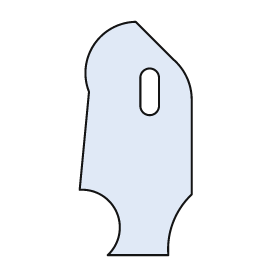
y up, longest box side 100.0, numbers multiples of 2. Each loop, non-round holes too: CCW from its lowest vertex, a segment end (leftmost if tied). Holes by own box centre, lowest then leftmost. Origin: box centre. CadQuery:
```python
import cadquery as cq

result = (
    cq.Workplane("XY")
    .moveTo(-12.0, -50.0)
    .lineTo(14.0, -50.0)
    .threePointArc((16.0, -36.0), (24.0, -24.0))
    .lineTo(24.0, 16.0)
    .threePointArc((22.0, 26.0), (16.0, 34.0))
    .lineTo(0.0, 50.0)
    .threePointArc((-18.0, 40.0), (-20.0, 20.0))
    .lineTo(-24.0, -22.0)
    .threePointArc((-8.0, -32.0), (-12.0, -50.0))
    .close()
    .moveTo(2.0, 14.0)
    .threePointArc((6.0, 10.0), (10.0, 14.0))
    .lineTo(10.0, 26.0)
    .threePointArc((6.0, 30.0), (2.0, 26.0))
    .close()
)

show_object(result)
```